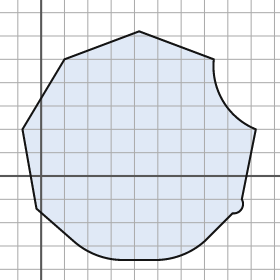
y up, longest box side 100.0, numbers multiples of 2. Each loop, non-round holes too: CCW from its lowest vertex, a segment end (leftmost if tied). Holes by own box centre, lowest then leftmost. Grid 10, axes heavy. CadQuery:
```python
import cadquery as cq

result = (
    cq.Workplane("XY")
    .moveTo(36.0, -36.0)
    .lineTo(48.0, -36.0)
    .threePointArc((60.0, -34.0), (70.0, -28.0))
    .lineTo(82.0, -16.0)
    .threePointArc((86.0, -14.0), (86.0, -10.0))
    .lineTo(92.0, 20.0)
    .threePointArc((78.0, 32.0), (74.0, 50.0))
    .lineTo(42.0, 62.0)
    .lineTo(10.0, 50.0)
    .lineTo(-8.0, 20.0)
    .lineTo(-2.0, -14.0)
    .lineTo(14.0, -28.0)
    .threePointArc((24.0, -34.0), (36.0, -36.0))
    .close()
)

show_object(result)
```